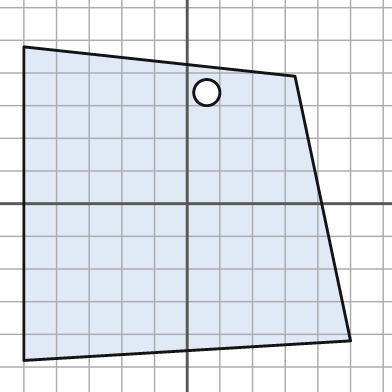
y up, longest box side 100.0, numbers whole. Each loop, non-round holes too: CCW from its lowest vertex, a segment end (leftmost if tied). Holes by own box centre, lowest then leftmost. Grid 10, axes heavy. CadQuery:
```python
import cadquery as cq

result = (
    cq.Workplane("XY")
    .moveTo(-50.0, -48.0)
    .lineTo(50.0, -42.0)
    .lineTo(33.0, 39.0)
    .lineTo(-50.0, 48.0)
    .close()
    .moveTo(6.0, 34.0)
    .circle(4.0)
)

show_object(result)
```